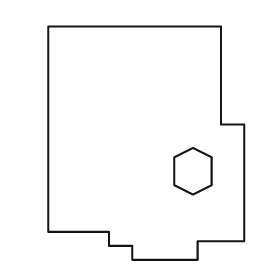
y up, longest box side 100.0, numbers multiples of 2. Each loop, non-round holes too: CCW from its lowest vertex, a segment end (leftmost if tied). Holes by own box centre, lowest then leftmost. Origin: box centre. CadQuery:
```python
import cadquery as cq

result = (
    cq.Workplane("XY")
    .moveTo(-6.0, -50.0)
    .lineTo(22.0, -50.0)
    .lineTo(22.0, -42.0)
    .lineTo(42.0, -42.0)
    .lineTo(42.0, 8.0)
    .lineTo(32.0, 8.0)
    .lineTo(32.0, 50.0)
    .lineTo(-42.0, 50.0)
    .lineTo(-42.0, -38.0)
    .lineTo(-16.0, -38.0)
    .lineTo(-16.0, -44.0)
    .lineTo(-6.0, -44.0)
    .close()
    .moveTo(20.0, -22.0)
    .lineTo(28.0, -18.0)
    .lineTo(28.0, -6.0)
    .lineTo(20.0, -2.0)
    .lineTo(12.0, -6.0)
    .lineTo(12.0, -18.0)
    .close()
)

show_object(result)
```